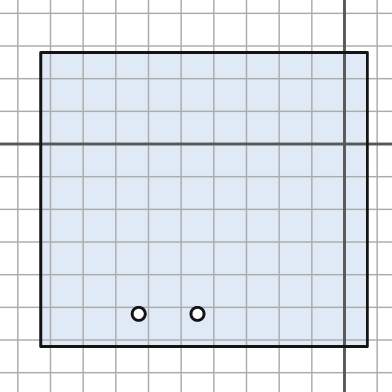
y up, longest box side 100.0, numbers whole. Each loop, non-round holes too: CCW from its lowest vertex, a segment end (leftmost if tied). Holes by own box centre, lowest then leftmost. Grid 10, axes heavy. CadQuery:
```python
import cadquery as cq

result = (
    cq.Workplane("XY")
    .moveTo(-93.0, -62.0)
    .lineTo(7.0, -62.0)
    .lineTo(7.0, 28.0)
    .lineTo(-93.0, 28.0)
    .close()
    .moveTo(-63.0, -52.0)
    .circle(2.0)
    .moveTo(-45.0, -52.0)
    .circle(2.0)
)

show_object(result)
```